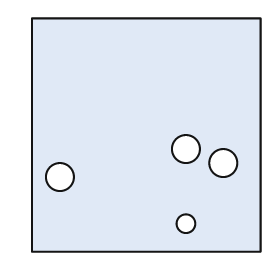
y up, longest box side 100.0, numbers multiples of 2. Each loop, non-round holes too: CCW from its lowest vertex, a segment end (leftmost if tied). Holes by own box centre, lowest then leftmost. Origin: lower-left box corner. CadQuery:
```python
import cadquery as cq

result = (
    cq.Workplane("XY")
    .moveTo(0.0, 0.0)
    .lineTo(98.0, 0.0)
    .lineTo(98.0, 100.0)
    .lineTo(0.0, 100.0)
    .close()
    .moveTo(66.0, 12.0)
    .circle(4.0)
    .moveTo(12.0, 32.0)
    .circle(6.0)
    .moveTo(82.0, 38.0)
    .circle(6.0)
    .moveTo(66.0, 44.0)
    .circle(6.0)
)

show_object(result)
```